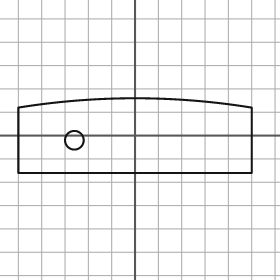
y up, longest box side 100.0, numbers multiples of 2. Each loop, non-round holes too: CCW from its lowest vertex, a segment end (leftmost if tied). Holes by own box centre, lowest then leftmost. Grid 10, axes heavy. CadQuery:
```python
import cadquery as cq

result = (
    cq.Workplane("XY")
    .moveTo(-50.0, -16.0)
    .lineTo(50.0, -16.0)
    .lineTo(50.0, 12.0)
    .threePointArc((0.0, 16.0), (-50.0, 12.0))
    .close()
    .moveTo(-26.0, -2.0)
    .circle(4.0)
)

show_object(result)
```